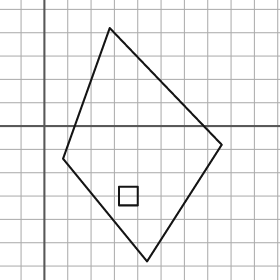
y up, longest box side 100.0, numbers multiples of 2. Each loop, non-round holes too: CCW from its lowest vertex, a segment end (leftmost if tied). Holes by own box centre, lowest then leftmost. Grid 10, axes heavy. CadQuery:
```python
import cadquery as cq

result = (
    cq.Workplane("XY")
    .moveTo(44.0, -58.0)
    .lineTo(76.0, -8.0)
    .lineTo(28.0, 42.0)
    .lineTo(8.0, -14.0)
    .close()
    .moveTo(32.0, -34.0)
    .lineTo(40.0, -34.0)
    .lineTo(40.0, -26.0)
    .lineTo(32.0, -26.0)
    .close()
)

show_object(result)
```